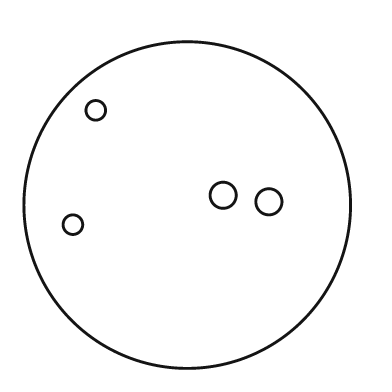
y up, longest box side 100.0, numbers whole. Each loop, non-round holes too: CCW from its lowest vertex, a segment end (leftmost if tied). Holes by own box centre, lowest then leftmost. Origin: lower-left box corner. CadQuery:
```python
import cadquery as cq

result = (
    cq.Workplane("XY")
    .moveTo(50.0, 50.0)
    .circle(50.0)
    .moveTo(15.0, 44.0)
    .circle(3.0)
    .moveTo(75.0, 51.0)
    .circle(4.0)
    .moveTo(61.0, 53.0)
    .circle(4.0)
    .moveTo(22.0, 79.0)
    .circle(3.0)
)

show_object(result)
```